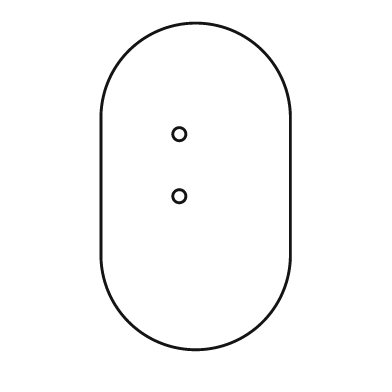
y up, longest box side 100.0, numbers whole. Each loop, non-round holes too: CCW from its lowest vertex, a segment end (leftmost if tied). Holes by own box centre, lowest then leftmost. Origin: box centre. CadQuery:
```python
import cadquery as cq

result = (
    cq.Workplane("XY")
    .moveTo(-29.0, -21.0)
    .threePointArc((0.0, -50.0), (29.0, -21.0))
    .lineTo(29.0, 21.0)
    .threePointArc((0.0, 50.0), (-29.0, 21.0))
    .close()
    .moveTo(-5.0, -3.0)
    .circle(2.0)
    .moveTo(-5.0, 16.0)
    .circle(2.0)
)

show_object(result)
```